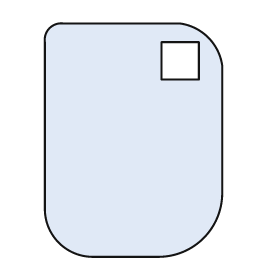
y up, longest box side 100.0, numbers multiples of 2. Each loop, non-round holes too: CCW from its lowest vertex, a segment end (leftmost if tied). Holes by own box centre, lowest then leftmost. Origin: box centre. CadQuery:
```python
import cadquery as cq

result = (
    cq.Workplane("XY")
    .moveTo(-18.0, -50.0)
    .lineTo(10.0, -50.0)
    .threePointArc((30.0, -42.0), (38.0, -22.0))
    .lineTo(38.0, 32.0)
    .threePointArc((32.0, 44.0), (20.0, 50.0))
    .lineTo(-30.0, 50.0)
    .threePointArc((-36.0, 48.0), (-38.0, 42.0))
    .lineTo(-38.0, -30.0)
    .threePointArc((-32.0, -44.0), (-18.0, -50.0))
    .close()
    .moveTo(12.0, 26.0)
    .lineTo(28.0, 26.0)
    .lineTo(28.0, 42.0)
    .lineTo(12.0, 42.0)
    .close()
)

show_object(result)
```